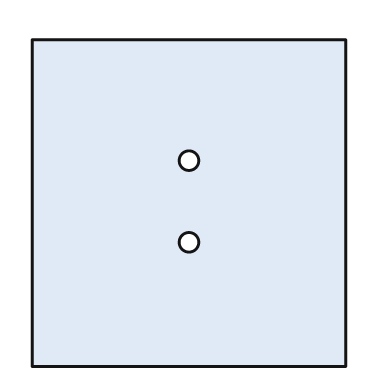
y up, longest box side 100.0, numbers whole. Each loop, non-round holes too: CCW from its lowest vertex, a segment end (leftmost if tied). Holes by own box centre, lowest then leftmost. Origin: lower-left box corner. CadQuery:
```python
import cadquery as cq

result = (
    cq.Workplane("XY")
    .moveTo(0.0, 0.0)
    .lineTo(96.0, 0.0)
    .lineTo(96.0, 100.0)
    .lineTo(0.0, 100.0)
    .close()
    .moveTo(48.0, 38.0)
    .circle(3.0)
    .moveTo(48.0, 63.0)
    .circle(3.0)
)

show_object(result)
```